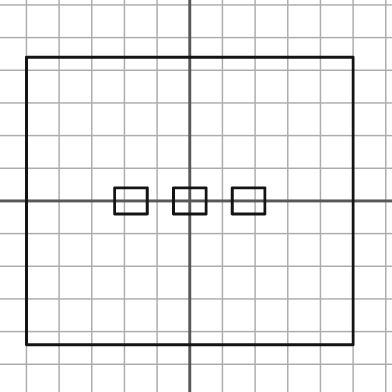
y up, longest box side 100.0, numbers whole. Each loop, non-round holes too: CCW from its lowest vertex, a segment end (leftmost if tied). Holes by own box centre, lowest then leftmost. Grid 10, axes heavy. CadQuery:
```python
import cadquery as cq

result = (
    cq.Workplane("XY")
    .moveTo(-50.0, -44.0)
    .lineTo(50.0, -44.0)
    .lineTo(50.0, 44.0)
    .lineTo(-50.0, 44.0)
    .close()
    .moveTo(-23.0, -4.0)
    .lineTo(-13.0, -4.0)
    .lineTo(-13.0, 4.0)
    .lineTo(-23.0, 4.0)
    .close()
    .moveTo(-5.0, -4.0)
    .lineTo(5.0, -4.0)
    .lineTo(5.0, 4.0)
    .lineTo(-5.0, 4.0)
    .close()
    .moveTo(13.0, -4.0)
    .lineTo(23.0, -4.0)
    .lineTo(23.0, 4.0)
    .lineTo(13.0, 4.0)
    .close()
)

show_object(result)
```